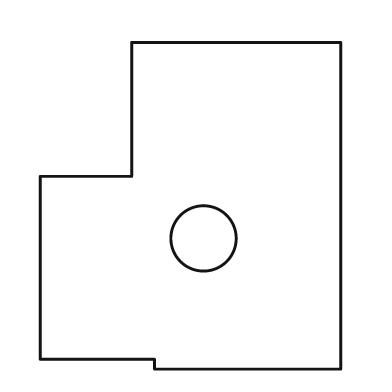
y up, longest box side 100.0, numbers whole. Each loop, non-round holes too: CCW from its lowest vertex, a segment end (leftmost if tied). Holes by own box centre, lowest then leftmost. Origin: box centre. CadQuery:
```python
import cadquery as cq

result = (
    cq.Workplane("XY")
    .moveTo(-11.0, -50.0)
    .lineTo(46.0, -50.0)
    .lineTo(46.0, 50.0)
    .lineTo(-18.0, 50.0)
    .lineTo(-18.0, 9.0)
    .lineTo(-46.0, 9.0)
    .lineTo(-46.0, -47.0)
    .lineTo(-11.0, -47.0)
    .close()
    .moveTo(4.0, -10.0)
    .circle(10.0)
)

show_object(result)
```